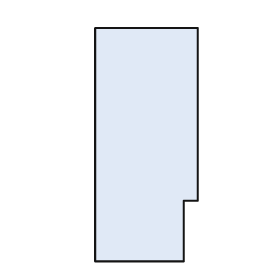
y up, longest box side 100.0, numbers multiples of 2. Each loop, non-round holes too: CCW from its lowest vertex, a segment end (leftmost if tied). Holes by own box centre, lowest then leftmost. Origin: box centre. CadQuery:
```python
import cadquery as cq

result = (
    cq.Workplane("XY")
    .moveTo(-22.0, -50.0)
    .lineTo(16.0, -50.0)
    .lineTo(16.0, -24.0)
    .lineTo(22.0, -24.0)
    .lineTo(22.0, 50.0)
    .lineTo(-22.0, 50.0)
    .close()
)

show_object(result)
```